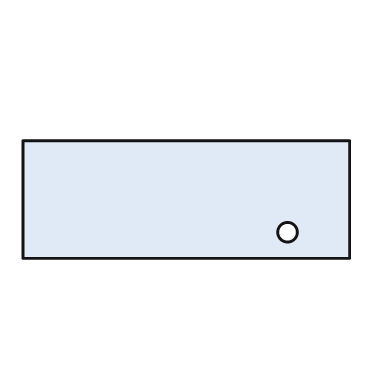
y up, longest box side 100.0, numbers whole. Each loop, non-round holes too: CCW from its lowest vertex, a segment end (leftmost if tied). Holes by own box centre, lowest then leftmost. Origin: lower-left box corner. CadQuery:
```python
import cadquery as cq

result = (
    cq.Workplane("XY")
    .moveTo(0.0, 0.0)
    .lineTo(100.0, 0.0)
    .lineTo(100.0, 36.0)
    .lineTo(0.0, 36.0)
    .close()
    .moveTo(81.0, 8.0)
    .circle(3.0)
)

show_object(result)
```